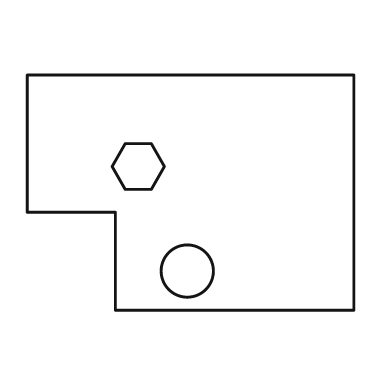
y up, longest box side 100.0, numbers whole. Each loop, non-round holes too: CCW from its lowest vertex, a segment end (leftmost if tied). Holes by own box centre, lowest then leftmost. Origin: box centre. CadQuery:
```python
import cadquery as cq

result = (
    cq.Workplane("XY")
    .moveTo(-23.0, -36.0)
    .lineTo(50.0, -36.0)
    .lineTo(50.0, 36.0)
    .lineTo(-50.0, 36.0)
    .lineTo(-50.0, -6.0)
    .lineTo(-23.0, -6.0)
    .close()
    .moveTo(-1.0, -24.0)
    .circle(8.0)
    .moveTo(-20.0, 1.0)
    .lineTo(-12.0, 1.0)
    .lineTo(-8.0, 8.0)
    .lineTo(-12.0, 15.0)
    .lineTo(-20.0, 15.0)
    .lineTo(-24.0, 8.0)
    .close()
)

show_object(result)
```